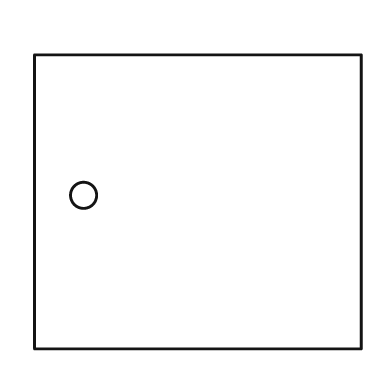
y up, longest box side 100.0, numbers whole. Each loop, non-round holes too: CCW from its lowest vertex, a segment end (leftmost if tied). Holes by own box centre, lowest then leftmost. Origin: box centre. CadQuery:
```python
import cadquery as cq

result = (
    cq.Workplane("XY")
    .moveTo(-50.0, -45.0)
    .lineTo(50.0, -45.0)
    .lineTo(50.0, 45.0)
    .lineTo(-50.0, 45.0)
    .close()
    .moveTo(-35.0, 2.0)
    .circle(4.0)
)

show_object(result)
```